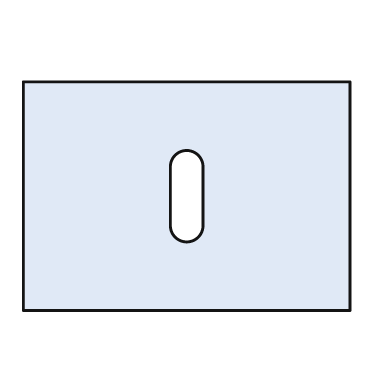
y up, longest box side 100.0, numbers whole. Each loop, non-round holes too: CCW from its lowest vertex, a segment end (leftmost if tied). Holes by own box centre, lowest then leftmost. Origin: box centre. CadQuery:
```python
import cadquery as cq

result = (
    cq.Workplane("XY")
    .moveTo(-50.0, -35.0)
    .lineTo(50.0, -35.0)
    .lineTo(50.0, 35.0)
    .lineTo(-50.0, 35.0)
    .close()
    .moveTo(-5.0, -9.0)
    .threePointArc((0.0, -14.0), (5.0, -9.0))
    .lineTo(5.0, 9.0)
    .threePointArc((0.0, 14.0), (-5.0, 9.0))
    .close()
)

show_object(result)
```